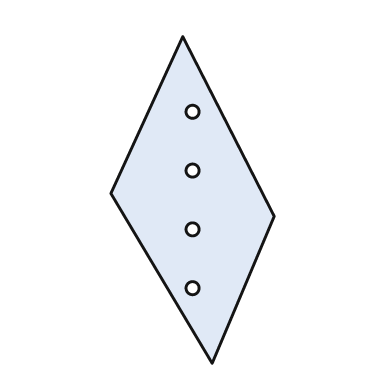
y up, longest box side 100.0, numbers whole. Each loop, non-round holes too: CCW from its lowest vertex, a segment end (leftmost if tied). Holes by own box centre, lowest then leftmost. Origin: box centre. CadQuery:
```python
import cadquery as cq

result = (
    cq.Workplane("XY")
    .moveTo(6.0, -50.0)
    .lineTo(25.0, -5.0)
    .lineTo(-3.0, 50.0)
    .lineTo(-25.0, 2.0)
    .close()
    .moveTo(0.0, -27.0)
    .circle(2.0)
    .moveTo(0.0, -9.0)
    .circle(2.0)
    .moveTo(0.0, 9.0)
    .circle(2.0)
    .moveTo(0.0, 27.0)
    .circle(2.0)
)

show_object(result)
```